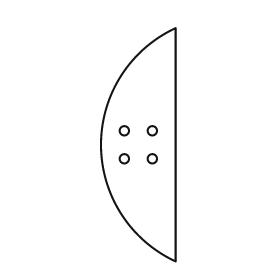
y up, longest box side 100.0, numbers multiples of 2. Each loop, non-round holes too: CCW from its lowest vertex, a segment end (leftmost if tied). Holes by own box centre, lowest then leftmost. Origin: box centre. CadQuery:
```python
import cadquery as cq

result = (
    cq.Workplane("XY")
    .moveTo(16.0, -50.0)
    .lineTo(16.0, 50.0)
    .threePointArc((-16.0, 0.0), (16.0, -50.0))
    .close()
    .moveTo(-6.0, -6.0)
    .circle(2.0)
    .moveTo(6.0, -6.0)
    .circle(2.0)
    .moveTo(-6.0, 6.0)
    .circle(2.0)
    .moveTo(6.0, 6.0)
    .circle(2.0)
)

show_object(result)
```